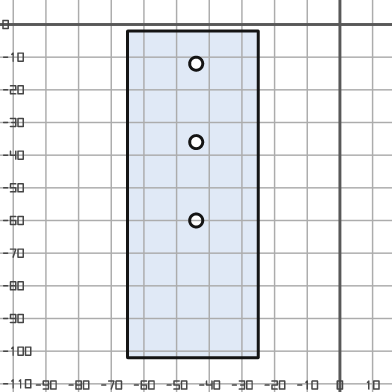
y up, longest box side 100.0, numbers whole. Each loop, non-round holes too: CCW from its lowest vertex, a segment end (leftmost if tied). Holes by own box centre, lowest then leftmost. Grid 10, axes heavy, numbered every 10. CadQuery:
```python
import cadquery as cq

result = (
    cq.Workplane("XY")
    .moveTo(-65.0, -102.0)
    .lineTo(-25.0, -102.0)
    .lineTo(-25.0, -2.0)
    .lineTo(-65.0, -2.0)
    .close()
    .moveTo(-44.0, -60.0)
    .circle(2.0)
    .moveTo(-44.0, -36.0)
    .circle(2.0)
    .moveTo(-44.0, -12.0)
    .circle(2.0)
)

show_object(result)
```